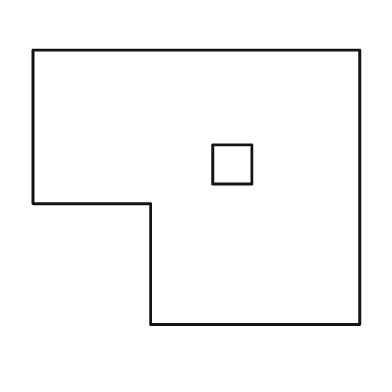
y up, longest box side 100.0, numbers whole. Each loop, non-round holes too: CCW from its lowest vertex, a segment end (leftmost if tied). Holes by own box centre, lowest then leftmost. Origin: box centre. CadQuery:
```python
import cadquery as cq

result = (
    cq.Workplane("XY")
    .moveTo(-14.0, -42.0)
    .lineTo(50.0, -42.0)
    .lineTo(50.0, 42.0)
    .lineTo(-50.0, 42.0)
    .lineTo(-50.0, -5.0)
    .lineTo(-14.0, -5.0)
    .close()
    .moveTo(5.0, 1.0)
    .lineTo(17.0, 1.0)
    .lineTo(17.0, 13.0)
    .lineTo(5.0, 13.0)
    .close()
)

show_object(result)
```